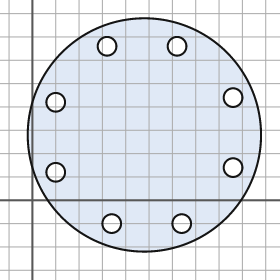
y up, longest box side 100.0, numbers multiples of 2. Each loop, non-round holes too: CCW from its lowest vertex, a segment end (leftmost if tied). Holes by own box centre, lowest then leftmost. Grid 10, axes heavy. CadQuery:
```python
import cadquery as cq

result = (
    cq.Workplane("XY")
    .moveTo(48.0, 28.0)
    .circle(50.0)
    .moveTo(34.0, -10.0)
    .circle(4.0)
    .moveTo(64.0, -10.0)
    .circle(4.0)
    .moveTo(10.0, 12.0)
    .circle(4.0)
    .moveTo(86.0, 14.0)
    .circle(4.0)
    .moveTo(10.0, 42.0)
    .circle(4.0)
    .moveTo(86.0, 44.0)
    .circle(4.0)
    .moveTo(32.0, 66.0)
    .circle(4.0)
    .moveTo(62.0, 66.0)
    .circle(4.0)
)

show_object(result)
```